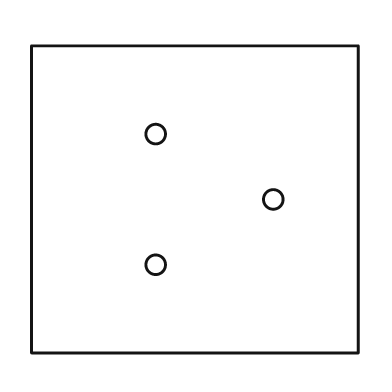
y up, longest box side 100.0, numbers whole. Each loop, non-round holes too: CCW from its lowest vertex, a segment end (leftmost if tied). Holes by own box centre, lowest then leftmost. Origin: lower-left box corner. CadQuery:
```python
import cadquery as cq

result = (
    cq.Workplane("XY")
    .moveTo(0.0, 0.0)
    .lineTo(100.0, 0.0)
    .lineTo(100.0, 94.0)
    .lineTo(0.0, 94.0)
    .close()
    .moveTo(38.0, 27.0)
    .circle(3.0)
    .moveTo(74.0, 47.0)
    .circle(3.0)
    .moveTo(38.0, 67.0)
    .circle(3.0)
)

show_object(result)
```